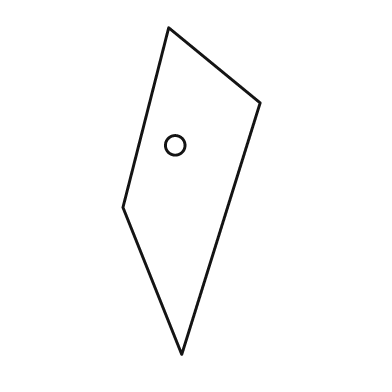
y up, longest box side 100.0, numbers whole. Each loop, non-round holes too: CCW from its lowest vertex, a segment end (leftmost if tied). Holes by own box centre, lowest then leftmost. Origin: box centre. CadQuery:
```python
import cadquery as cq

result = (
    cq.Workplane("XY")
    .moveTo(-3.0, -50.0)
    .lineTo(21.0, 27.0)
    .lineTo(-7.0, 50.0)
    .lineTo(-21.0, -5.0)
    .close()
    .moveTo(-5.0, 14.0)
    .circle(3.0)
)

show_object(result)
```